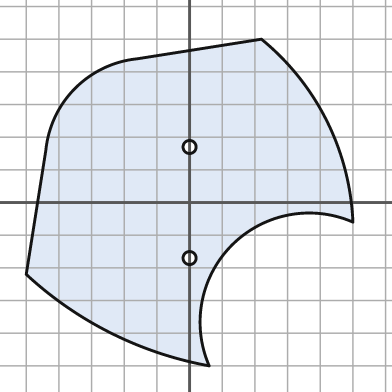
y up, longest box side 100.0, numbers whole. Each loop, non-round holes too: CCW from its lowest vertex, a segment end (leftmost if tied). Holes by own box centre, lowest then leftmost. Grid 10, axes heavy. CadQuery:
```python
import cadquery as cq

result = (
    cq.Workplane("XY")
    .moveTo(6.0, -50.0)
    .threePointArc((13.0, -13.0), (50.0, -6.0))
    .threePointArc((42.0, 25.0), (22.0, 50.0))
    .lineTo(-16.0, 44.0)
    .threePointArc((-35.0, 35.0), (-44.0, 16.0))
    .lineTo(-50.0, -22.0)
    .threePointArc((-24.0, -40.0), (6.0, -50.0))
    .close()
    .moveTo(0.0, -17.0)
    .circle(2.0)
    .moveTo(0.0, 17.0)
    .circle(2.0)
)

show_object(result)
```